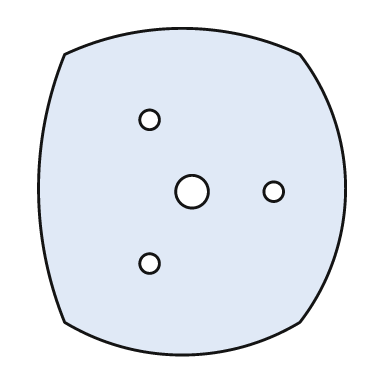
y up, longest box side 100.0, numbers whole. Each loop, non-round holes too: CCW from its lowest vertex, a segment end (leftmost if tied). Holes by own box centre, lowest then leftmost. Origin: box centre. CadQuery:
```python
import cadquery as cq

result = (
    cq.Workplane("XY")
    .moveTo(-39.0, -40.0)
    .threePointArc((-3.0, -50.0), (33.0, -40.0))
    .threePointArc((47.0, 1.0), (33.0, 42.0))
    .threePointArc((-3.0, 50.0), (-39.0, 42.0))
    .threePointArc((-47.0, 1.0), (-39.0, -40.0))
    .close()
    .moveTo(-13.0, -22.0)
    .circle(3.0)
    .moveTo(0.0, 0.0)
    .circle(5.0)
    .moveTo(25.0, 0.0)
    .circle(3.0)
    .moveTo(-13.0, 22.0)
    .circle(3.0)
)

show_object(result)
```